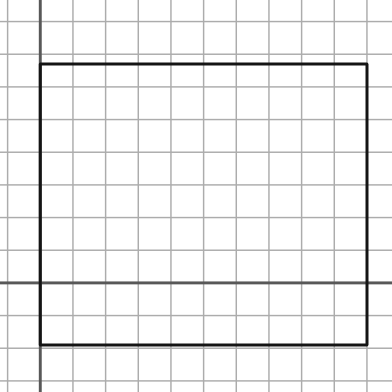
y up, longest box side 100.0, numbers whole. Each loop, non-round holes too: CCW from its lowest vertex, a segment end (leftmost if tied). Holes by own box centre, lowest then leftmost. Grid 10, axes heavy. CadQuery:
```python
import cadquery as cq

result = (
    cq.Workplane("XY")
    .moveTo(0.0, -19.0)
    .lineTo(100.0, -19.0)
    .lineTo(100.0, 67.0)
    .lineTo(0.0, 67.0)
    .close()
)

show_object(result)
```